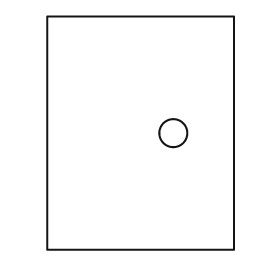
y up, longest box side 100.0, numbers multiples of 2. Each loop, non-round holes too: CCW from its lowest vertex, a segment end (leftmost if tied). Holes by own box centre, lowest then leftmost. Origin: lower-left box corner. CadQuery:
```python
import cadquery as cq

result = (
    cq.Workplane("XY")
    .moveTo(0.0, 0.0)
    .lineTo(80.0, 0.0)
    .lineTo(80.0, 100.0)
    .lineTo(0.0, 100.0)
    .close()
    .moveTo(54.0, 50.0)
    .circle(6.0)
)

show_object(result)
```